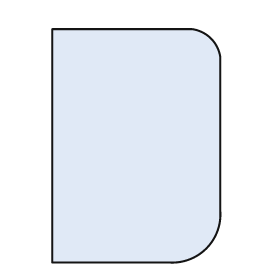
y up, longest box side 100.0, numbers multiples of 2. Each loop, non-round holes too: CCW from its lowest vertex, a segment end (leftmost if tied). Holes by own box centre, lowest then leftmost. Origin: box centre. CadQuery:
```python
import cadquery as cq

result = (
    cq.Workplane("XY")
    .moveTo(-36.0, -50.0)
    .lineTo(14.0, -50.0)
    .threePointArc((30.0, -44.0), (36.0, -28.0))
    .lineTo(36.0, 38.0)
    .threePointArc((32.0, 46.0), (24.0, 50.0))
    .lineTo(-36.0, 50.0)
    .close()
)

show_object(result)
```